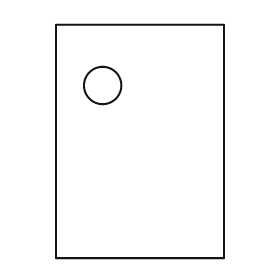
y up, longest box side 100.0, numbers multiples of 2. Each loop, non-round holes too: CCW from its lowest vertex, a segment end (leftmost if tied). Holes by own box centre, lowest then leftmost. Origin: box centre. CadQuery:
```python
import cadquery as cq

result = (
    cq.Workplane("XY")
    .moveTo(-36.0, -50.0)
    .lineTo(36.0, -50.0)
    .lineTo(36.0, 50.0)
    .lineTo(-36.0, 50.0)
    .close()
    .moveTo(-16.0, 24.0)
    .circle(8.0)
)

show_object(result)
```